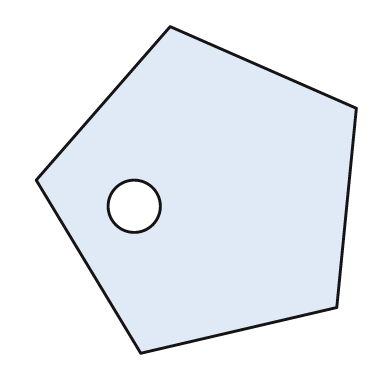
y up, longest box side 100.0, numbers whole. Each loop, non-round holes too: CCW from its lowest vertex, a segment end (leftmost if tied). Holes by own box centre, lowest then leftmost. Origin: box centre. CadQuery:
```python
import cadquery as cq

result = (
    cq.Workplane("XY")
    .moveTo(-17.0, -50.0)
    .lineTo(43.0, -36.0)
    .lineTo(49.0, 25.0)
    .lineTo(-8.0, 50.0)
    .lineTo(-49.0, 3.0)
    .close()
    .moveTo(-19.0, -5.0)
    .circle(8.0)
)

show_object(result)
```